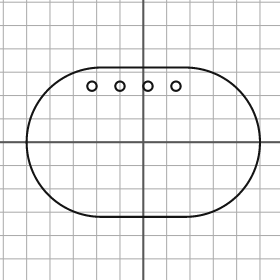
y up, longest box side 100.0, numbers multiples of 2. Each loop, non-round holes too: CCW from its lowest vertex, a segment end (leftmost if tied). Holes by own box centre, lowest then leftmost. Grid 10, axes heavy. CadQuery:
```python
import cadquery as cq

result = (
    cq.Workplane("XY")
    .moveTo(-18.0, -32.0)
    .lineTo(18.0, -32.0)
    .threePointArc((50.0, 0.0), (18.0, 32.0))
    .lineTo(-18.0, 32.0)
    .threePointArc((-50.0, 0.0), (-18.0, -32.0))
    .close()
    .moveTo(-22.0, 24.0)
    .circle(2.0)
    .moveTo(-10.0, 24.0)
    .circle(2.0)
    .moveTo(2.0, 24.0)
    .circle(2.0)
    .moveTo(14.0, 24.0)
    .circle(2.0)
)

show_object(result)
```